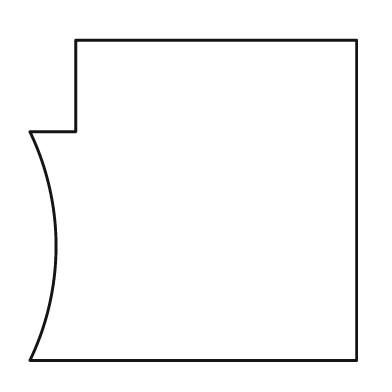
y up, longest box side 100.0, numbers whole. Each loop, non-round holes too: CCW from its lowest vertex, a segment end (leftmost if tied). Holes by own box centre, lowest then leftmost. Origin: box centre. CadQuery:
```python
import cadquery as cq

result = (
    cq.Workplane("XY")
    .moveTo(-50.0, -49.0)
    .lineTo(50.0, -49.0)
    .lineTo(50.0, 49.0)
    .lineTo(-36.0, 49.0)
    .lineTo(-36.0, 21.0)
    .lineTo(-50.0, 21.0)
    .threePointArc((-42.0, -14.0), (-50.0, -49.0))
    .close()
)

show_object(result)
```